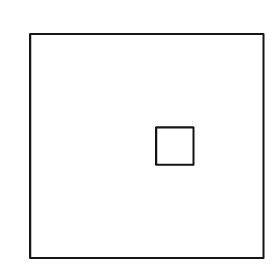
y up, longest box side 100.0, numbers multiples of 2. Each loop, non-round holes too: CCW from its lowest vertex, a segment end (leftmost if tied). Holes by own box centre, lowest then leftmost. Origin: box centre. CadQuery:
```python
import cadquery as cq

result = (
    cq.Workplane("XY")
    .moveTo(-50.0, -48.0)
    .lineTo(50.0, -48.0)
    .lineTo(50.0, 48.0)
    .lineTo(-50.0, 48.0)
    .close()
    .moveTo(4.0, -8.0)
    .lineTo(20.0, -8.0)
    .lineTo(20.0, 8.0)
    .lineTo(4.0, 8.0)
    .close()
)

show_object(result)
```